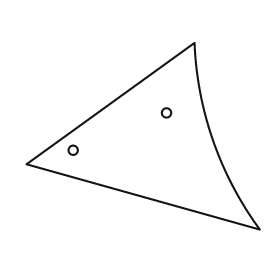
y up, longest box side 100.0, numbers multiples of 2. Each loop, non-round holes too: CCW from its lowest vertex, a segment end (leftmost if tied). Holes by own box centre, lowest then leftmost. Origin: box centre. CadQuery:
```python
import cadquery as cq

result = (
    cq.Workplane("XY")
    .moveTo(50.0, -40.0)
    .threePointArc((30.0, -2.0), (22.0, 40.0))
    .lineTo(-50.0, -12.0)
    .close()
    .moveTo(-30.0, -6.0)
    .circle(2.0)
    .moveTo(10.0, 10.0)
    .circle(2.0)
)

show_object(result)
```